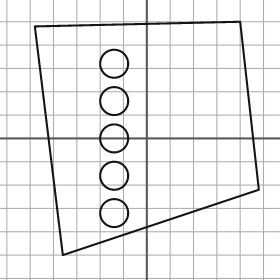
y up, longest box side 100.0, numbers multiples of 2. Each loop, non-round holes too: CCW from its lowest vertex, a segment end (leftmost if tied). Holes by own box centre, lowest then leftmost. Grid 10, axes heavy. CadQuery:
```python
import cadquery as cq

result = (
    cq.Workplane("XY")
    .moveTo(-36.0, -50.0)
    .lineTo(48.0, -22.0)
    .lineTo(40.0, 50.0)
    .lineTo(-48.0, 48.0)
    .close()
    .moveTo(-14.0, -32.0)
    .circle(6.0)
    .moveTo(-14.0, -16.0)
    .circle(6.0)
    .moveTo(-14.0, 0.0)
    .circle(6.0)
    .moveTo(-14.0, 16.0)
    .circle(6.0)
    .moveTo(-14.0, 32.0)
    .circle(6.0)
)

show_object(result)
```